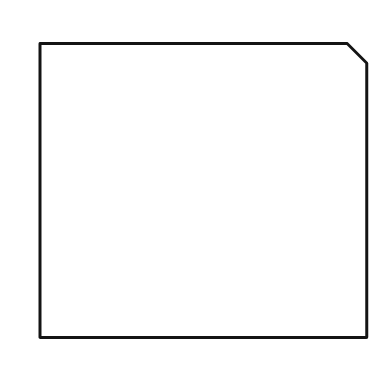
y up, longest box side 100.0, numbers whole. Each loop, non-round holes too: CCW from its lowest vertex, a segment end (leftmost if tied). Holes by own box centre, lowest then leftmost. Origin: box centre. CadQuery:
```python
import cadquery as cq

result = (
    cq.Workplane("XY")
    .moveTo(-50.0, -45.0)
    .lineTo(50.0, -45.0)
    .lineTo(50.0, 39.0)
    .lineTo(44.0, 45.0)
    .lineTo(-50.0, 45.0)
    .close()
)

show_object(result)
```